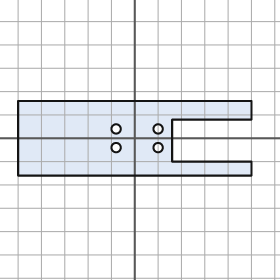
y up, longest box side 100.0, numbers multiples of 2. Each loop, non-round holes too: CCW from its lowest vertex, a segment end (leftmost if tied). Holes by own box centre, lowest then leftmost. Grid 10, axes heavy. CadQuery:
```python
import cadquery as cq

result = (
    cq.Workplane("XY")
    .moveTo(-50.0, -16.0)
    .lineTo(50.0, -16.0)
    .lineTo(50.0, -10.0)
    .lineTo(16.0, -10.0)
    .lineTo(16.0, 8.0)
    .lineTo(50.0, 8.0)
    .lineTo(50.0, 16.0)
    .lineTo(-50.0, 16.0)
    .close()
    .moveTo(-8.0, -4.0)
    .circle(2.0)
    .moveTo(10.0, -4.0)
    .circle(2.0)
    .moveTo(-8.0, 4.0)
    .circle(2.0)
    .moveTo(10.0, 4.0)
    .circle(2.0)
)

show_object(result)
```